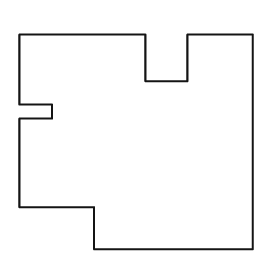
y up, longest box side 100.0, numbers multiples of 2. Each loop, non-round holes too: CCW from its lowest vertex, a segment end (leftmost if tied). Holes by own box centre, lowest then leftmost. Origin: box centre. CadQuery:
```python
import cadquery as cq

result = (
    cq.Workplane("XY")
    .moveTo(-18.0, -46.0)
    .lineTo(50.0, -46.0)
    .lineTo(50.0, 46.0)
    .lineTo(22.0, 46.0)
    .lineTo(22.0, 26.0)
    .lineTo(4.0, 26.0)
    .lineTo(4.0, 46.0)
    .lineTo(-50.0, 46.0)
    .lineTo(-50.0, 16.0)
    .lineTo(-36.0, 16.0)
    .lineTo(-36.0, 10.0)
    .lineTo(-50.0, 10.0)
    .lineTo(-50.0, -28.0)
    .lineTo(-18.0, -28.0)
    .close()
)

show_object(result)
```